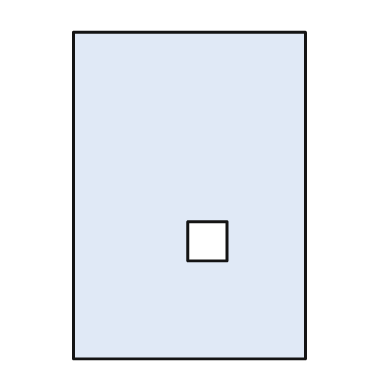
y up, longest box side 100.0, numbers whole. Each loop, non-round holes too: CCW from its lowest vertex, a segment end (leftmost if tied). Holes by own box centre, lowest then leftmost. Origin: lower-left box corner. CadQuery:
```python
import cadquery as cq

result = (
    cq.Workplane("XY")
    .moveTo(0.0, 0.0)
    .lineTo(71.0, 0.0)
    .lineTo(71.0, 100.0)
    .lineTo(0.0, 100.0)
    .close()
    .moveTo(35.0, 30.0)
    .lineTo(47.0, 30.0)
    .lineTo(47.0, 42.0)
    .lineTo(35.0, 42.0)
    .close()
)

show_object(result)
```